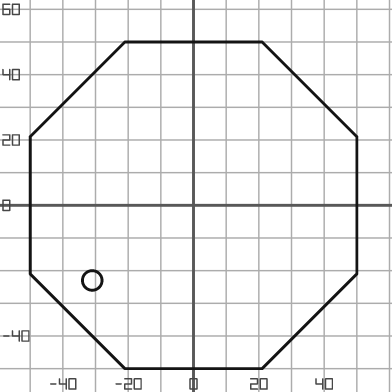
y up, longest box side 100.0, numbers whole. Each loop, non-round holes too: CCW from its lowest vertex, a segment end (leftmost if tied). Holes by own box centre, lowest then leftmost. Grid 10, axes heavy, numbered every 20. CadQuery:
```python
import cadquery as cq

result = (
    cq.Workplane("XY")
    .moveTo(-21.0, -50.0)
    .lineTo(21.0, -50.0)
    .lineTo(50.0, -21.0)
    .lineTo(50.0, 21.0)
    .lineTo(21.0, 50.0)
    .lineTo(-21.0, 50.0)
    .lineTo(-50.0, 21.0)
    .lineTo(-50.0, -21.0)
    .close()
    .moveTo(-31.0, -23.0)
    .circle(3.0)
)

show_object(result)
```